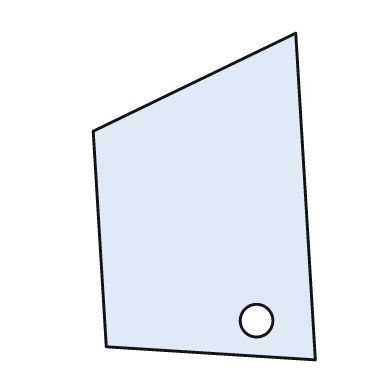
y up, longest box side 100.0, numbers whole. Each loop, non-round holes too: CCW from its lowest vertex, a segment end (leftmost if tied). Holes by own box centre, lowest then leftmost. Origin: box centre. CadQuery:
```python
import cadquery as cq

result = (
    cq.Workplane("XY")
    .moveTo(34.0, -50.0)
    .lineTo(28.0, 50.0)
    .lineTo(-34.0, 20.0)
    .lineTo(-30.0, -46.0)
    .close()
    .moveTo(16.0, -38.0)
    .circle(5.0)
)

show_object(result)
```